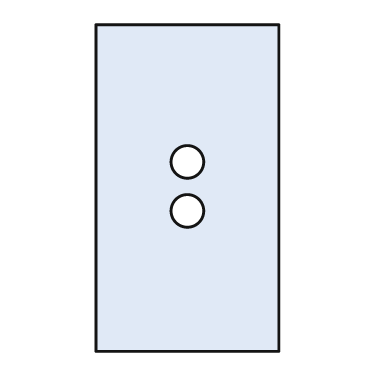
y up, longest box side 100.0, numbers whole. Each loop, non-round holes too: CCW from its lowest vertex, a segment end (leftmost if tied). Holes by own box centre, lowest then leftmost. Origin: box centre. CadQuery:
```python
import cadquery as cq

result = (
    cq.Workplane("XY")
    .moveTo(-28.0, -50.0)
    .lineTo(28.0, -50.0)
    .lineTo(28.0, 50.0)
    .lineTo(-28.0, 50.0)
    .close()
    .moveTo(0.0, -7.0)
    .circle(5.0)
    .moveTo(0.0, 8.0)
    .circle(5.0)
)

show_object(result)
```